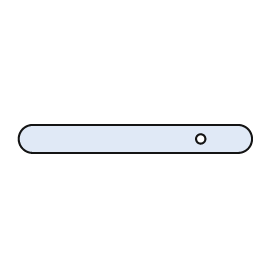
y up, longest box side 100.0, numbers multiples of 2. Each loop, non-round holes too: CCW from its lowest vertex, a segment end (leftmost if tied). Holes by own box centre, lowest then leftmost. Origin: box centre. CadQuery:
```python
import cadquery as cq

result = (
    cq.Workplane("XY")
    .moveTo(-44.0, -6.0)
    .lineTo(44.0, -6.0)
    .threePointArc((50.0, 0.0), (44.0, 6.0))
    .lineTo(-44.0, 6.0)
    .threePointArc((-50.0, 0.0), (-44.0, -6.0))
    .close()
    .moveTo(28.0, 0.0)
    .circle(2.0)
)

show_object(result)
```